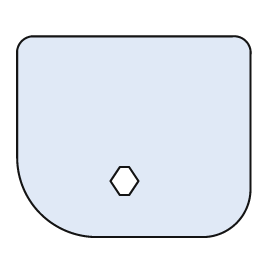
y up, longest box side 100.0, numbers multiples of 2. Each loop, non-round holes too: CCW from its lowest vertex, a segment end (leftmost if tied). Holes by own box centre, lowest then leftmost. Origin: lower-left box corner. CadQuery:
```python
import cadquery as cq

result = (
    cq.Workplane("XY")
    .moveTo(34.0, 0.0)
    .lineTo(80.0, 0.0)
    .threePointArc((94.0, 6.0), (100.0, 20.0))
    .lineTo(100.0, 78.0)
    .threePointArc((98.0, 84.0), (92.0, 86.0))
    .lineTo(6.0, 86.0)
    .threePointArc((2.0, 84.0), (0.0, 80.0))
    .lineTo(0.0, 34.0)
    .threePointArc((10.0, 10.0), (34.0, 0.0))
    .close()
    .moveTo(44.0, 18.0)
    .lineTo(48.0, 18.0)
    .lineTo(52.0, 24.0)
    .lineTo(48.0, 30.0)
    .lineTo(44.0, 30.0)
    .lineTo(40.0, 24.0)
    .close()
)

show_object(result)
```